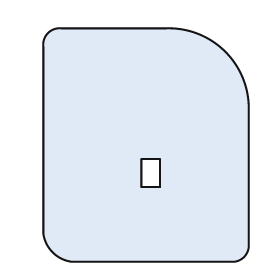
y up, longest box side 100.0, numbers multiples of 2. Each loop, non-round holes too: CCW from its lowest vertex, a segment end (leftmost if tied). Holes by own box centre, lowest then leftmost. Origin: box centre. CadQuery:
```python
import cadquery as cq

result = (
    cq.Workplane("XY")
    .moveTo(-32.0, -50.0)
    .lineTo(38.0, -50.0)
    .threePointArc((42.0, -48.0), (44.0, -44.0))
    .lineTo(44.0, 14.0)
    .threePointArc((34.0, 40.0), (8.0, 50.0))
    .lineTo(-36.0, 50.0)
    .threePointArc((-42.0, 48.0), (-44.0, 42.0))
    .lineTo(-44.0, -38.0)
    .threePointArc((-40.0, -46.0), (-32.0, -50.0))
    .close()
    .moveTo(-2.0, -18.0)
    .lineTo(6.0, -18.0)
    .lineTo(6.0, -6.0)
    .lineTo(-2.0, -6.0)
    .close()
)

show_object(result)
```